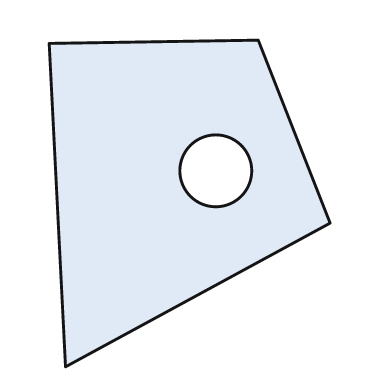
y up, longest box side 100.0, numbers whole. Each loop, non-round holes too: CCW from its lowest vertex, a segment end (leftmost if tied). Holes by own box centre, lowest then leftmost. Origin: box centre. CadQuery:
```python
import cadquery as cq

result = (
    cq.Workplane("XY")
    .moveTo(-38.0, -50.0)
    .lineTo(43.0, -6.0)
    .lineTo(21.0, 50.0)
    .lineTo(-43.0, 49.0)
    .close()
    .moveTo(8.0, 10.0)
    .circle(11.0)
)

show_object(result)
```